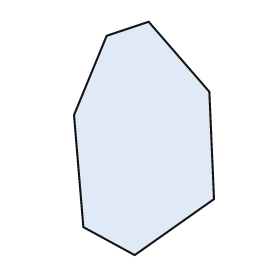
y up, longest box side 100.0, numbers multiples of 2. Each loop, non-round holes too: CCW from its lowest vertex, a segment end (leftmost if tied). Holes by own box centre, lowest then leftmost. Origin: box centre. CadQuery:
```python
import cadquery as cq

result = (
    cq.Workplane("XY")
    .moveTo(-4.0, -50.0)
    .lineTo(30.0, -26.0)
    .lineTo(28.0, 20.0)
    .lineTo(2.0, 50.0)
    .lineTo(-16.0, 44.0)
    .lineTo(-30.0, 10.0)
    .lineTo(-26.0, -38.0)
    .close()
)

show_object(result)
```